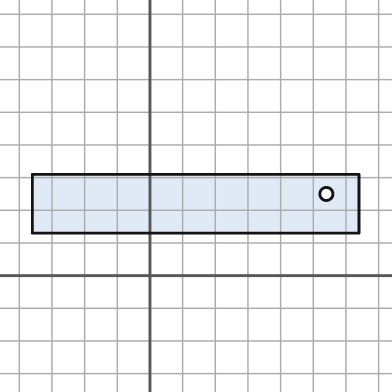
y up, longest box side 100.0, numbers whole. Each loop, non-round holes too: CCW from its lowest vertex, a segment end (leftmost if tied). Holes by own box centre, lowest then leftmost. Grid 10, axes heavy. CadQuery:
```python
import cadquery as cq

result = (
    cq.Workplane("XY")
    .moveTo(-36.0, 13.0)
    .lineTo(64.0, 13.0)
    .lineTo(64.0, 31.0)
    .lineTo(-36.0, 31.0)
    .close()
    .moveTo(54.0, 25.0)
    .circle(2.0)
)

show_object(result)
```